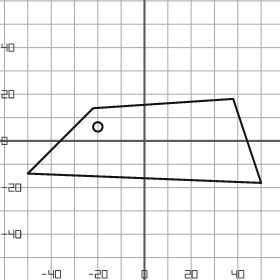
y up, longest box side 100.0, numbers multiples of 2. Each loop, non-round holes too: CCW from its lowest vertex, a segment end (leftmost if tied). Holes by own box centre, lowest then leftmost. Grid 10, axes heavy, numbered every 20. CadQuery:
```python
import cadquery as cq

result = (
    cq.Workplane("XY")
    .moveTo(50.0, -18.0)
    .lineTo(38.0, 18.0)
    .lineTo(-22.0, 14.0)
    .lineTo(-50.0, -14.0)
    .close()
    .moveTo(-20.0, 6.0)
    .circle(2.0)
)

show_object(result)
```